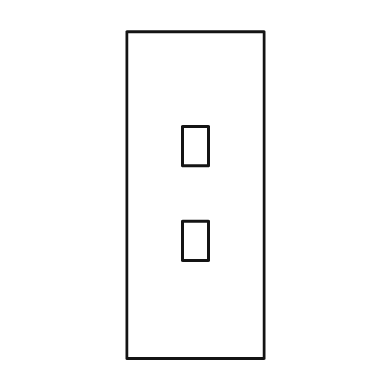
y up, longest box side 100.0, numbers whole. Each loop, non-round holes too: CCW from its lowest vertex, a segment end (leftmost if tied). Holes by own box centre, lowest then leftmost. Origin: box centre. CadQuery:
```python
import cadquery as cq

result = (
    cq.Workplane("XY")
    .moveTo(-21.0, -50.0)
    .lineTo(21.0, -50.0)
    .lineTo(21.0, 50.0)
    .lineTo(-21.0, 50.0)
    .close()
    .moveTo(-4.0, -20.0)
    .lineTo(4.0, -20.0)
    .lineTo(4.0, -8.0)
    .lineTo(-4.0, -8.0)
    .close()
    .moveTo(-4.0, 9.0)
    .lineTo(4.0, 9.0)
    .lineTo(4.0, 21.0)
    .lineTo(-4.0, 21.0)
    .close()
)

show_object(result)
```